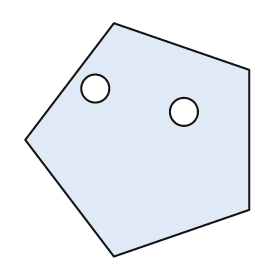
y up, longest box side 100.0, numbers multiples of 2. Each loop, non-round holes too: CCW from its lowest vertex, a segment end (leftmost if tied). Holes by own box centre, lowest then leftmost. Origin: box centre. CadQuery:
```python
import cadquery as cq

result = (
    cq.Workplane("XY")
    .moveTo(-10.0, -50.0)
    .lineTo(48.0, -30.0)
    .lineTo(48.0, 30.0)
    .lineTo(-10.0, 50.0)
    .lineTo(-48.0, 0.0)
    .close()
    .moveTo(20.0, 12.0)
    .circle(6.0)
    .moveTo(-18.0, 22.0)
    .circle(6.0)
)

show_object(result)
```